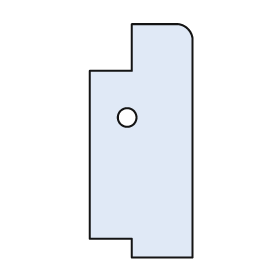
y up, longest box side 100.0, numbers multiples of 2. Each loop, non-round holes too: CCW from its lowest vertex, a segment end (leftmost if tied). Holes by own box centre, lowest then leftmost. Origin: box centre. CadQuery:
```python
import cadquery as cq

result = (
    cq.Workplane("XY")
    .moveTo(-4.0, -50.0)
    .lineTo(22.0, -50.0)
    .lineTo(22.0, 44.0)
    .threePointArc((20.0, 48.0), (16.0, 50.0))
    .lineTo(-4.0, 50.0)
    .lineTo(-4.0, 30.0)
    .lineTo(-22.0, 30.0)
    .lineTo(-22.0, -42.0)
    .lineTo(-4.0, -42.0)
    .close()
    .moveTo(-6.0, 10.0)
    .circle(4.0)
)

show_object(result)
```